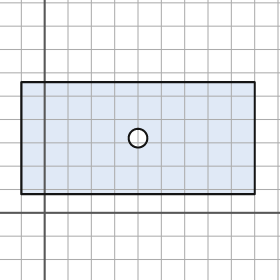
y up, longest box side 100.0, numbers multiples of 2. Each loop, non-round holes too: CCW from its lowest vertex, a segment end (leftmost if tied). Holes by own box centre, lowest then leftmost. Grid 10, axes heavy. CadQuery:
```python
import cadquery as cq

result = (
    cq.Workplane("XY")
    .moveTo(-10.0, 8.0)
    .lineTo(90.0, 8.0)
    .lineTo(90.0, 56.0)
    .lineTo(-10.0, 56.0)
    .close()
    .moveTo(40.0, 32.0)
    .circle(4.0)
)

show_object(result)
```